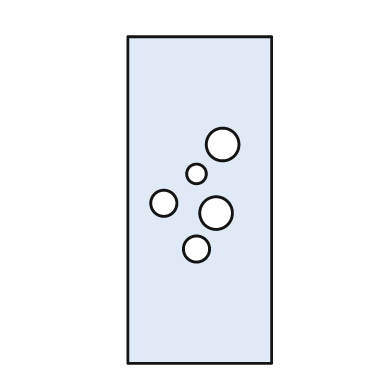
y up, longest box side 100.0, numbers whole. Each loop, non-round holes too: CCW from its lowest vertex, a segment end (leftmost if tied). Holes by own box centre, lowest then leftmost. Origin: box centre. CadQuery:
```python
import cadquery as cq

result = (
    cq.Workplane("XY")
    .moveTo(-22.0, -50.0)
    .lineTo(22.0, -50.0)
    .lineTo(22.0, 50.0)
    .lineTo(-22.0, 50.0)
    .close()
    .moveTo(-1.0, -15.0)
    .circle(4.0)
    .moveTo(5.0, -4.0)
    .circle(5.0)
    .moveTo(-11.0, -1.0)
    .circle(4.0)
    .moveTo(-1.0, 8.0)
    .circle(3.0)
    .moveTo(7.0, 17.0)
    .circle(5.0)
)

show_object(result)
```